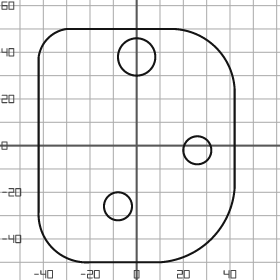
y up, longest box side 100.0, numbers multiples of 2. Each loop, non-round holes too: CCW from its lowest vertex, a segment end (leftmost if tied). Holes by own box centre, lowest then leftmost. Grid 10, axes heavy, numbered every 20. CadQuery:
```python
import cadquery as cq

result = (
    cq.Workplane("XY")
    .moveTo(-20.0, -50.0)
    .lineTo(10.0, -50.0)
    .threePointArc((32.0, -40.0), (42.0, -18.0))
    .lineTo(42.0, 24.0)
    .threePointArc((34.0, 42.0), (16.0, 50.0))
    .lineTo(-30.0, 50.0)
    .threePointArc((-38.0, 46.0), (-42.0, 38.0))
    .lineTo(-42.0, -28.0)
    .threePointArc((-36.0, -44.0), (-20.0, -50.0))
    .close()
    .moveTo(-8.0, -26.0)
    .circle(6.0)
    .moveTo(26.0, -2.0)
    .circle(6.0)
    .moveTo(0.0, 38.0)
    .circle(8.0)
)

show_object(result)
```